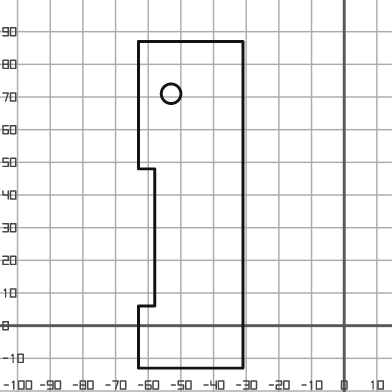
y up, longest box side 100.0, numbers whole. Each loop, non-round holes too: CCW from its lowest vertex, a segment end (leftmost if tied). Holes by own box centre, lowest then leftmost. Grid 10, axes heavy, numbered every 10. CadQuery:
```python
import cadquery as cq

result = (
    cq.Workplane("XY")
    .moveTo(-63.0, -13.0)
    .lineTo(-31.0, -13.0)
    .lineTo(-31.0, 87.0)
    .lineTo(-63.0, 87.0)
    .lineTo(-63.0, 48.0)
    .lineTo(-58.0, 48.0)
    .lineTo(-58.0, 6.0)
    .lineTo(-63.0, 6.0)
    .close()
    .moveTo(-53.0, 71.0)
    .circle(3.0)
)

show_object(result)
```